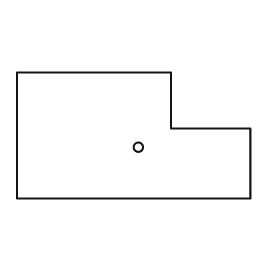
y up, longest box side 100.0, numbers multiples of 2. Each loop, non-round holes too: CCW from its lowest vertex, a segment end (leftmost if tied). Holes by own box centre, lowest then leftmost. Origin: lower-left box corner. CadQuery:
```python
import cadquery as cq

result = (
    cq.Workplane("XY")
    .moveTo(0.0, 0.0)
    .lineTo(100.0, 0.0)
    .lineTo(100.0, 30.0)
    .lineTo(66.0, 30.0)
    .lineTo(66.0, 54.0)
    .lineTo(0.0, 54.0)
    .close()
    .moveTo(52.0, 22.0)
    .circle(2.0)
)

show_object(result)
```